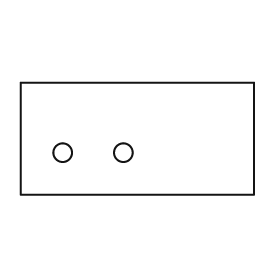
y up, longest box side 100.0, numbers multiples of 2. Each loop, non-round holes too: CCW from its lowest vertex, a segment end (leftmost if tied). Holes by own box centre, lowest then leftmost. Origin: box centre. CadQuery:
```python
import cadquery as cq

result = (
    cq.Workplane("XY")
    .moveTo(-50.0, -24.0)
    .lineTo(50.0, -24.0)
    .lineTo(50.0, 24.0)
    .lineTo(-50.0, 24.0)
    .close()
    .moveTo(-32.0, -6.0)
    .circle(4.0)
    .moveTo(-6.0, -6.0)
    .circle(4.0)
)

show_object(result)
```